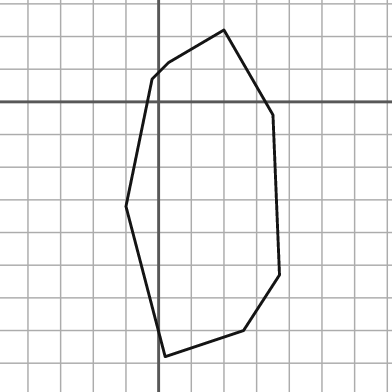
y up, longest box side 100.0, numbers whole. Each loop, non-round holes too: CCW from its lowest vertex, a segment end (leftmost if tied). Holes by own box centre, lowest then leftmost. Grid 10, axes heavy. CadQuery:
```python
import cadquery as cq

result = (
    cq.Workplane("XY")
    .moveTo(2.0, -78.0)
    .lineTo(26.0, -70.0)
    .lineTo(37.0, -53.0)
    .lineTo(35.0, -4.0)
    .lineTo(20.0, 22.0)
    .lineTo(3.0, 12.0)
    .lineTo(-2.0, 7.0)
    .lineTo(-10.0, -32.0)
    .close()
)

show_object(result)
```